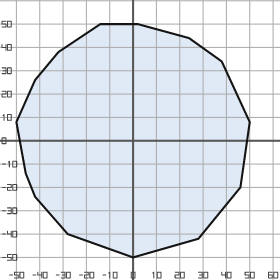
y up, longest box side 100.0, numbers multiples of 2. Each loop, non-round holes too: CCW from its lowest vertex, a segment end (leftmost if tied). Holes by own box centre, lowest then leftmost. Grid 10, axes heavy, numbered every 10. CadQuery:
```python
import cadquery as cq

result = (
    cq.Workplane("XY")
    .moveTo(0.0, -50.0)
    .lineTo(28.0, -42.0)
    .lineTo(46.0, -20.0)
    .lineTo(50.0, 8.0)
    .lineTo(38.0, 34.0)
    .lineTo(24.0, 44.0)
    .lineTo(2.0, 50.0)
    .lineTo(-14.0, 50.0)
    .lineTo(-32.0, 38.0)
    .lineTo(-42.0, 26.0)
    .lineTo(-50.0, 8.0)
    .lineTo(-46.0, -14.0)
    .lineTo(-42.0, -24.0)
    .lineTo(-28.0, -40.0)
    .close()
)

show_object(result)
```